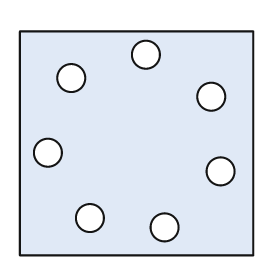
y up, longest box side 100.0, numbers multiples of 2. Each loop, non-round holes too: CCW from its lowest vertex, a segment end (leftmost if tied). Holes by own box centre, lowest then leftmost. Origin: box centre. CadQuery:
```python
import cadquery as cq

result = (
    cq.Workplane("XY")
    .moveTo(-50.0, -48.0)
    .lineTo(50.0, -48.0)
    .lineTo(50.0, 48.0)
    .lineTo(-50.0, 48.0)
    .close()
    .moveTo(12.0, -36.0)
    .circle(6.0)
    .moveTo(-20.0, -32.0)
    .circle(6.0)
    .moveTo(36.0, -12.0)
    .circle(6.0)
    .moveTo(-38.0, -4.0)
    .circle(6.0)
    .moveTo(32.0, 20.0)
    .circle(6.0)
    .moveTo(-28.0, 28.0)
    .circle(6.0)
    .moveTo(4.0, 38.0)
    .circle(6.0)
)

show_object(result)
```